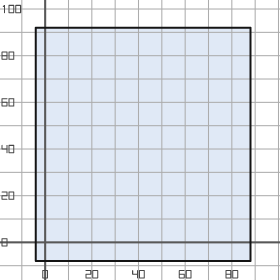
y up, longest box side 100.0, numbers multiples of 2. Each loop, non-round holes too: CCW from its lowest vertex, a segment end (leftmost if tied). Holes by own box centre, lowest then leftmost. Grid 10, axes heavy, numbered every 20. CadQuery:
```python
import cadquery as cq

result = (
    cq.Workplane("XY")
    .moveTo(-4.0, -8.0)
    .lineTo(88.0, -8.0)
    .lineTo(88.0, 92.0)
    .lineTo(-4.0, 92.0)
    .close()
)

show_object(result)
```